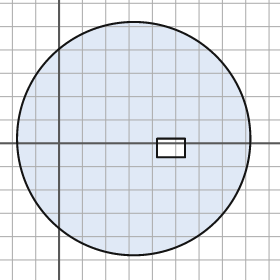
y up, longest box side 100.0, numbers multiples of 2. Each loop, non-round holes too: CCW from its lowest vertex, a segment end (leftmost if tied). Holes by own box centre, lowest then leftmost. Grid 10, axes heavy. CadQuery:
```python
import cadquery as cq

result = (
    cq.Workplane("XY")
    .moveTo(32.0, 2.0)
    .circle(50.0)
    .moveTo(42.0, -6.0)
    .lineTo(54.0, -6.0)
    .lineTo(54.0, 2.0)
    .lineTo(42.0, 2.0)
    .close()
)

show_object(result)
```